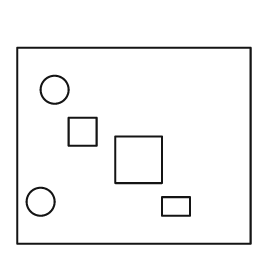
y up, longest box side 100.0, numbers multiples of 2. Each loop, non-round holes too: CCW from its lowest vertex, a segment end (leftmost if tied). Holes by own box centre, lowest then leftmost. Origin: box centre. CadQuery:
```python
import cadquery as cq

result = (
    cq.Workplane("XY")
    .moveTo(-50.0, -42.0)
    .lineTo(50.0, -42.0)
    .lineTo(50.0, 42.0)
    .lineTo(-50.0, 42.0)
    .close()
    .moveTo(12.0, -30.0)
    .lineTo(24.0, -30.0)
    .lineTo(24.0, -22.0)
    .lineTo(12.0, -22.0)
    .close()
    .moveTo(-40.0, -24.0)
    .circle(6.0)
    .moveTo(-8.0, -16.0)
    .lineTo(12.0, -16.0)
    .lineTo(12.0, 4.0)
    .lineTo(-8.0, 4.0)
    .close()
    .moveTo(-28.0, 0.0)
    .lineTo(-16.0, 0.0)
    .lineTo(-16.0, 12.0)
    .lineTo(-28.0, 12.0)
    .close()
    .moveTo(-34.0, 24.0)
    .circle(6.0)
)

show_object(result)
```